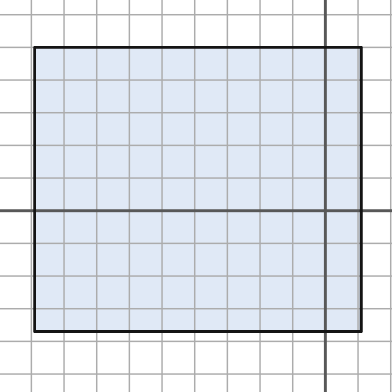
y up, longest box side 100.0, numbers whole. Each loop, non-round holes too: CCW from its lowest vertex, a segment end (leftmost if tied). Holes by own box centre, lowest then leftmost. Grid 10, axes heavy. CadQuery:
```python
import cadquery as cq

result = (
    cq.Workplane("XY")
    .moveTo(-89.0, -37.0)
    .lineTo(11.0, -37.0)
    .lineTo(11.0, 50.0)
    .lineTo(-89.0, 50.0)
    .close()
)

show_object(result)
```